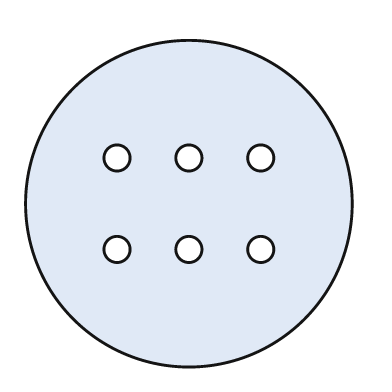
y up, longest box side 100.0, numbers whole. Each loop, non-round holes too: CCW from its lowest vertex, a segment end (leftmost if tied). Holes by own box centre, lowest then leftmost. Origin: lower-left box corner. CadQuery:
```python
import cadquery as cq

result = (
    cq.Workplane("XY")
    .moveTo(50.0, 50.0)
    .circle(50.0)
    .moveTo(28.0, 36.0)
    .circle(4.0)
    .moveTo(50.0, 36.0)
    .circle(4.0)
    .moveTo(72.0, 36.0)
    .circle(4.0)
    .moveTo(28.0, 64.0)
    .circle(4.0)
    .moveTo(50.0, 64.0)
    .circle(4.0)
    .moveTo(72.0, 64.0)
    .circle(4.0)
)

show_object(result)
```